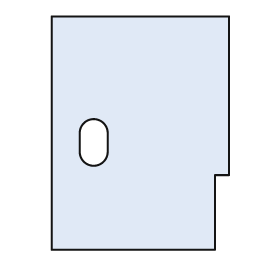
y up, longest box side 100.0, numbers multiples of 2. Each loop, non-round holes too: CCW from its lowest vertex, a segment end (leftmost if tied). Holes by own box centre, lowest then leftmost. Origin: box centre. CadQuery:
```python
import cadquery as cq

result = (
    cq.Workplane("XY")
    .moveTo(-38.0, -50.0)
    .lineTo(32.0, -50.0)
    .lineTo(32.0, -18.0)
    .lineTo(38.0, -18.0)
    .lineTo(38.0, 50.0)
    .lineTo(-38.0, 50.0)
    .close()
    .moveTo(-26.0, -8.0)
    .threePointArc((-20.0, -14.0), (-14.0, -8.0))
    .lineTo(-14.0, 0.0)
    .threePointArc((-20.0, 6.0), (-26.0, 0.0))
    .close()
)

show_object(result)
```